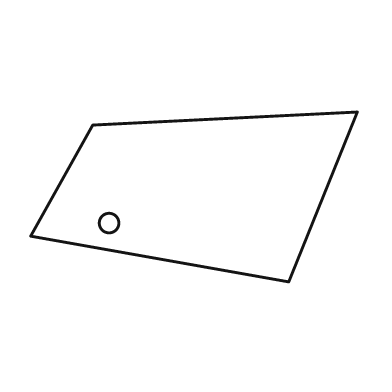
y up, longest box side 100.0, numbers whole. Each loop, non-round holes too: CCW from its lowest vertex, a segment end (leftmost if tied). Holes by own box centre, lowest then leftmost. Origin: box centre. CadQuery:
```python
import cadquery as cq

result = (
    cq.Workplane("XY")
    .moveTo(29.0, -26.0)
    .lineTo(50.0, 26.0)
    .lineTo(-31.0, 22.0)
    .lineTo(-50.0, -12.0)
    .close()
    .moveTo(-26.0, -8.0)
    .circle(3.0)
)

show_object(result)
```